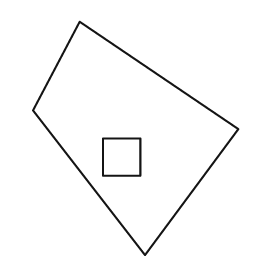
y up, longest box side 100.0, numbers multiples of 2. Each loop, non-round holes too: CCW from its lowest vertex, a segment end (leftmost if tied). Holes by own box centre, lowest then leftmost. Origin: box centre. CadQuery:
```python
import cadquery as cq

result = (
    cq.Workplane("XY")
    .moveTo(4.0, -50.0)
    .lineTo(44.0, 4.0)
    .lineTo(-24.0, 50.0)
    .lineTo(-44.0, 12.0)
    .close()
    .moveTo(-14.0, -16.0)
    .lineTo(2.0, -16.0)
    .lineTo(2.0, 0.0)
    .lineTo(-14.0, 0.0)
    .close()
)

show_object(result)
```